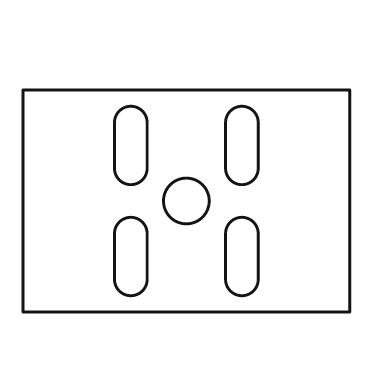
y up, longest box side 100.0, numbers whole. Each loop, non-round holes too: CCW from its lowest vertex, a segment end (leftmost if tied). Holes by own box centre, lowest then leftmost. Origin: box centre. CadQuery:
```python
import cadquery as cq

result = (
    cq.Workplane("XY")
    .moveTo(-50.0, -34.0)
    .lineTo(50.0, -34.0)
    .lineTo(50.0, 34.0)
    .lineTo(-50.0, 34.0)
    .close()
    .moveTo(-22.0, -24.0)
    .threePointArc((-17.0, -29.0), (-12.0, -24.0))
    .lineTo(-12.0, -10.0)
    .threePointArc((-17.0, -5.0), (-22.0, -10.0))
    .close()
    .moveTo(12.0, -24.0)
    .threePointArc((17.0, -29.0), (22.0, -24.0))
    .lineTo(22.0, -10.0)
    .threePointArc((17.0, -5.0), (12.0, -10.0))
    .close()
    .moveTo(0.0, 0.0)
    .circle(7.0)
    .moveTo(-22.0, 10.0)
    .threePointArc((-17.0, 5.0), (-12.0, 10.0))
    .lineTo(-12.0, 24.0)
    .threePointArc((-17.0, 29.0), (-22.0, 24.0))
    .close()
    .moveTo(12.0, 10.0)
    .threePointArc((17.0, 5.0), (22.0, 10.0))
    .lineTo(22.0, 24.0)
    .threePointArc((17.0, 29.0), (12.0, 24.0))
    .close()
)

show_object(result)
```